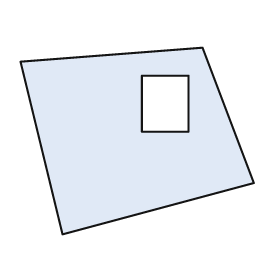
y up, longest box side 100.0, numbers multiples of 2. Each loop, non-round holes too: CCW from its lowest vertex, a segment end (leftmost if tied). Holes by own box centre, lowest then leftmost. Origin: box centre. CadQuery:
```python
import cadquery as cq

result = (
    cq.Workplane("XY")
    .moveTo(-32.0, -40.0)
    .lineTo(50.0, -18.0)
    .lineTo(28.0, 40.0)
    .lineTo(-50.0, 34.0)
    .close()
    .moveTo(2.0, 4.0)
    .lineTo(22.0, 4.0)
    .lineTo(22.0, 28.0)
    .lineTo(2.0, 28.0)
    .close()
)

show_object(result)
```